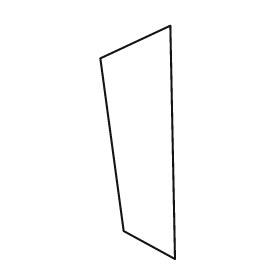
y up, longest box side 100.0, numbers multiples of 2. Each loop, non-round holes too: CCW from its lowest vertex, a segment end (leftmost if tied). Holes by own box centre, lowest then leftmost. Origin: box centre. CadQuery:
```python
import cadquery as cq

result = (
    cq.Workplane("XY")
    .moveTo(16.0, -50.0)
    .lineTo(14.0, 50.0)
    .lineTo(-16.0, 36.0)
    .lineTo(-6.0, -38.0)
    .close()
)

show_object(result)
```